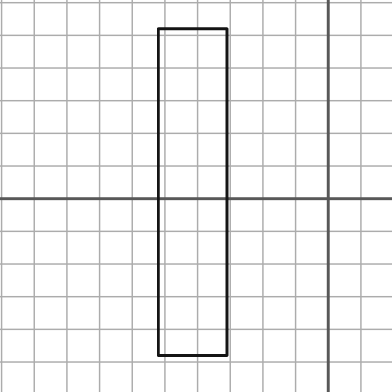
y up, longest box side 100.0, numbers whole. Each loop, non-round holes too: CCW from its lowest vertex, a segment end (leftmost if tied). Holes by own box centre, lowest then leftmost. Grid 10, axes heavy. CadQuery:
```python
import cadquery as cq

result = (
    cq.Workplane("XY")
    .moveTo(-52.0, -48.0)
    .lineTo(-31.0, -48.0)
    .lineTo(-31.0, 52.0)
    .lineTo(-52.0, 52.0)
    .close()
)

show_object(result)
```